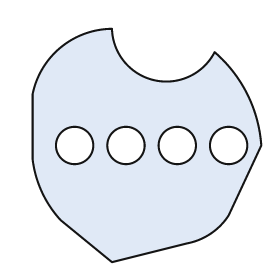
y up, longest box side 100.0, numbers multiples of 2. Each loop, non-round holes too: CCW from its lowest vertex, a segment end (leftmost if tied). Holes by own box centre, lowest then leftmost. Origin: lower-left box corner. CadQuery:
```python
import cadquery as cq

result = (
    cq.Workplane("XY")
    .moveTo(34.0, 0.0)
    .lineTo(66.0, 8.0)
    .threePointArc((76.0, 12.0), (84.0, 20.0))
    .lineTo(98.0, 50.0)
    .threePointArc((92.0, 72.0), (78.0, 90.0))
    .threePointArc((52.0, 78.0), (34.0, 100.0))
    .threePointArc((12.0, 92.0), (0.0, 72.0))
    .lineTo(0.0, 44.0)
    .threePointArc((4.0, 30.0), (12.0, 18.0))
    .close()
    .moveTo(18.0, 50.0)
    .circle(8.0)
    .moveTo(40.0, 50.0)
    .circle(8.0)
    .moveTo(62.0, 50.0)
    .circle(8.0)
    .moveTo(84.0, 50.0)
    .circle(8.0)
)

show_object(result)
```